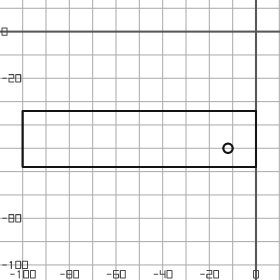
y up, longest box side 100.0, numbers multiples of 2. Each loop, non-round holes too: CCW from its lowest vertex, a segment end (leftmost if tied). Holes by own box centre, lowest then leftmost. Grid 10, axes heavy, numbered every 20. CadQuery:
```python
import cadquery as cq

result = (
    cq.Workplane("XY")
    .moveTo(-100.0, -58.0)
    .lineTo(0.0, -58.0)
    .lineTo(0.0, -34.0)
    .lineTo(-100.0, -34.0)
    .close()
    .moveTo(-12.0, -50.0)
    .circle(2.0)
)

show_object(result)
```